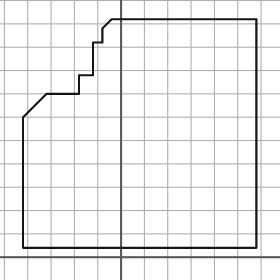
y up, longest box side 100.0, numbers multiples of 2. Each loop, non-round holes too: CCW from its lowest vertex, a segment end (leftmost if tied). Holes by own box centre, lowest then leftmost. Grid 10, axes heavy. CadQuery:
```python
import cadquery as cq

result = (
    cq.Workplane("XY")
    .moveTo(-42.0, 4.0)
    .lineTo(58.0, 4.0)
    .lineTo(58.0, 102.0)
    .lineTo(-4.0, 102.0)
    .lineTo(-8.0, 98.0)
    .lineTo(-8.0, 92.0)
    .lineTo(-12.0, 92.0)
    .lineTo(-12.0, 78.0)
    .lineTo(-18.0, 78.0)
    .lineTo(-18.0, 70.0)
    .lineTo(-32.0, 70.0)
    .lineTo(-42.0, 60.0)
    .close()
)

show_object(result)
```